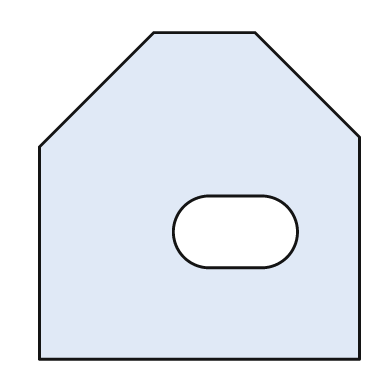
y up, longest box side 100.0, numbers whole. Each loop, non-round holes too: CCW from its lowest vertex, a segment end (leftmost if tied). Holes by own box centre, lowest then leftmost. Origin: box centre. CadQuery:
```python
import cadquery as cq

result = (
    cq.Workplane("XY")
    .moveTo(-49.0, -50.0)
    .lineTo(49.0, -50.0)
    .lineTo(49.0, 18.0)
    .lineTo(17.0, 50.0)
    .lineTo(-14.0, 50.0)
    .lineTo(-49.0, 15.0)
    .close()
    .moveTo(3.0, -22.0)
    .lineTo(19.0, -22.0)
    .threePointArc((30.0, -11.0), (19.0, 0.0))
    .lineTo(3.0, 0.0)
    .threePointArc((-8.0, -11.0), (3.0, -22.0))
    .close()
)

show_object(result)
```